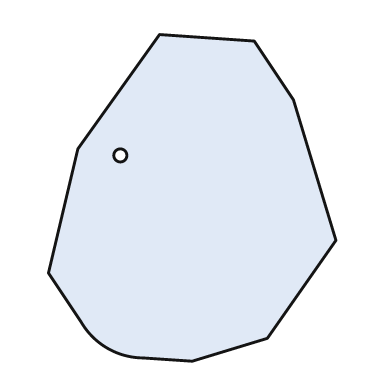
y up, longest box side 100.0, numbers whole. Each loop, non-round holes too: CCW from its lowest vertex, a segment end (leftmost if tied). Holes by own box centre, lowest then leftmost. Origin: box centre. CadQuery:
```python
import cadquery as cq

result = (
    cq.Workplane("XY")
    .moveTo(0.0, -50.0)
    .lineTo(23.0, -43.0)
    .lineTo(44.0, -13.0)
    .lineTo(31.0, 30.0)
    .lineTo(19.0, 48.0)
    .lineTo(-10.0, 50.0)
    .lineTo(-35.0, 15.0)
    .lineTo(-44.0, -23.0)
    .lineTo(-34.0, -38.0)
    .threePointArc((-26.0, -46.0), (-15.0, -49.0))
    .close()
    .moveTo(-22.0, 13.0)
    .circle(2.0)
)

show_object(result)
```